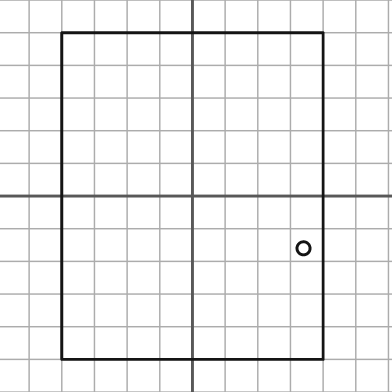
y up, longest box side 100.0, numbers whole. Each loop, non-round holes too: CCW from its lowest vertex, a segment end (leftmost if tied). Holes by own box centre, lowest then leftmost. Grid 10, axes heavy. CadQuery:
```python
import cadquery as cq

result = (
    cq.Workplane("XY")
    .moveTo(-40.0, -50.0)
    .lineTo(40.0, -50.0)
    .lineTo(40.0, 50.0)
    .lineTo(-40.0, 50.0)
    .close()
    .moveTo(34.0, -16.0)
    .circle(2.0)
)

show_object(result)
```